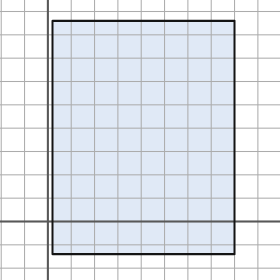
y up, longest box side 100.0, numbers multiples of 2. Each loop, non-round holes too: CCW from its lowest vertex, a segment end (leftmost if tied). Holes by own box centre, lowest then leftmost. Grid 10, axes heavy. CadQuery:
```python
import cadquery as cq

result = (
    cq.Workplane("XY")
    .moveTo(2.0, -14.0)
    .lineTo(80.0, -14.0)
    .lineTo(80.0, 86.0)
    .lineTo(2.0, 86.0)
    .close()
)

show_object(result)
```